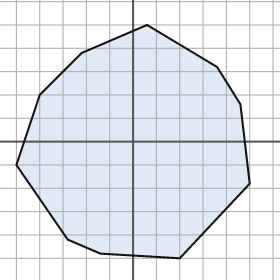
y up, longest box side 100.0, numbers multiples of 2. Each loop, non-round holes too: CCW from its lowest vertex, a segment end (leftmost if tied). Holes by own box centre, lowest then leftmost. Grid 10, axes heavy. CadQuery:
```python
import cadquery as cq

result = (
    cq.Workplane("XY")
    .moveTo(20.0, -50.0)
    .lineTo(50.0, -18.0)
    .lineTo(46.0, 16.0)
    .lineTo(36.0, 32.0)
    .lineTo(6.0, 50.0)
    .lineTo(-22.0, 38.0)
    .lineTo(-40.0, 20.0)
    .lineTo(-50.0, -10.0)
    .lineTo(-28.0, -42.0)
    .lineTo(-14.0, -48.0)
    .close()
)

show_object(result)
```